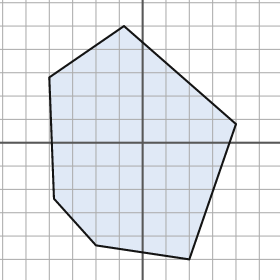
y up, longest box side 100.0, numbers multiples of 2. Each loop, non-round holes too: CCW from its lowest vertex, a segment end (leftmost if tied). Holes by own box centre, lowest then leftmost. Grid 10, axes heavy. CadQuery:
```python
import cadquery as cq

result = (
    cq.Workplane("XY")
    .moveTo(20.0, -50.0)
    .lineTo(40.0, 8.0)
    .lineTo(-8.0, 50.0)
    .lineTo(-40.0, 28.0)
    .lineTo(-38.0, -24.0)
    .lineTo(-20.0, -44.0)
    .close()
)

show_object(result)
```